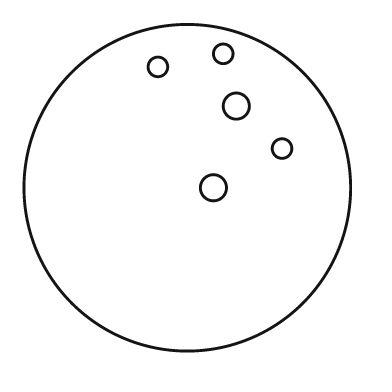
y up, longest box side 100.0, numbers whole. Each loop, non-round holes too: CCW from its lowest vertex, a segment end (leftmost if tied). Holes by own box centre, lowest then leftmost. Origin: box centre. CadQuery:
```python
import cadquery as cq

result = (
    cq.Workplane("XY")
    .moveTo(0.0, 0.0)
    .circle(50.0)
    .moveTo(8.0, 0.0)
    .circle(4.0)
    .moveTo(29.0, 12.0)
    .circle(3.0)
    .moveTo(15.0, 25.0)
    .circle(4.0)
    .moveTo(-9.0, 37.0)
    .circle(3.0)
    .moveTo(11.0, 41.0)
    .circle(3.0)
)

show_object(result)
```